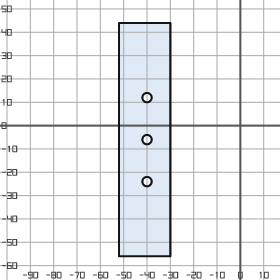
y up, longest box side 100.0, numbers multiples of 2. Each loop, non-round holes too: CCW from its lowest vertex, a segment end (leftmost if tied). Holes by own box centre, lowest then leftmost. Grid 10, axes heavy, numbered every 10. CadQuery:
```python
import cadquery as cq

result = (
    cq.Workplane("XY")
    .moveTo(-52.0, -56.0)
    .lineTo(-30.0, -56.0)
    .lineTo(-30.0, 44.0)
    .lineTo(-52.0, 44.0)
    .close()
    .moveTo(-40.0, -24.0)
    .circle(2.0)
    .moveTo(-40.0, -6.0)
    .circle(2.0)
    .moveTo(-40.0, 12.0)
    .circle(2.0)
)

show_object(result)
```